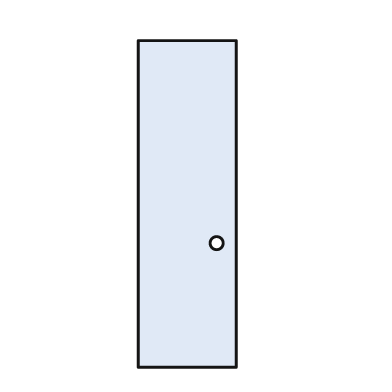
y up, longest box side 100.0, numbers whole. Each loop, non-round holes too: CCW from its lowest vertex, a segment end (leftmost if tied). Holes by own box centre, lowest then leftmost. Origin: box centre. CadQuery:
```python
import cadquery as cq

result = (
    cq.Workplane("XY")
    .moveTo(-15.0, -50.0)
    .lineTo(15.0, -50.0)
    .lineTo(15.0, 50.0)
    .lineTo(-15.0, 50.0)
    .close()
    .moveTo(9.0, -12.0)
    .circle(2.0)
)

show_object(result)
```